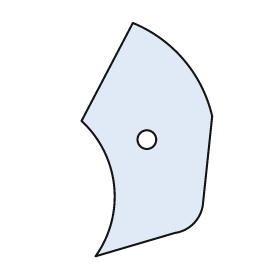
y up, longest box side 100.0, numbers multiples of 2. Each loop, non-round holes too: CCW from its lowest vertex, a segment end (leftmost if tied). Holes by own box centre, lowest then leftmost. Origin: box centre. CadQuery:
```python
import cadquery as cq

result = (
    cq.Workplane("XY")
    .moveTo(-22.0, -50.0)
    .lineTo(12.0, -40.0)
    .threePointArc((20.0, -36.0), (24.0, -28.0))
    .lineTo(28.0, 10.0)
    .threePointArc((16.0, 34.0), (-6.0, 50.0))
    .lineTo(-28.0, 8.0)
    .threePointArc((-14.0, -20.0), (-22.0, -50.0))
    .close()
    .moveTo(0.0, 0.0)
    .circle(4.0)
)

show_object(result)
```